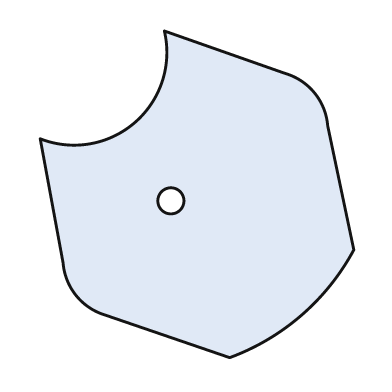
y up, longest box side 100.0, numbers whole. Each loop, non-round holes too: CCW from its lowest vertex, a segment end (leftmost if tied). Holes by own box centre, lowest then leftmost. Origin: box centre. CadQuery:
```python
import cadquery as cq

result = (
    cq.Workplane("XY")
    .moveTo(10.0, -50.0)
    .threePointArc((32.0, -37.0), (48.0, -17.0))
    .lineTo(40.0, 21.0)
    .threePointArc((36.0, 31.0), (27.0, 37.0))
    .lineTo(-10.0, 50.0)
    .threePointArc((-19.0, 22.0), (-48.0, 17.0))
    .lineTo(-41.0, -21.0)
    .threePointArc((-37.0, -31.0), (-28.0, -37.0))
    .close()
    .moveTo(-8.0, -2.0)
    .circle(4.0)
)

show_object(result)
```